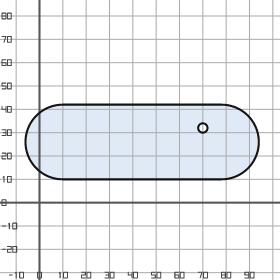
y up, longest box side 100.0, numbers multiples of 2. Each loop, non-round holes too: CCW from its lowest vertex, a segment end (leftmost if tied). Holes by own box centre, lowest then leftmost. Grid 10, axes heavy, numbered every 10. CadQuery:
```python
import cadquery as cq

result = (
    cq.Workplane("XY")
    .moveTo(10.0, 10.0)
    .lineTo(78.0, 10.0)
    .threePointArc((94.0, 26.0), (78.0, 42.0))
    .lineTo(10.0, 42.0)
    .threePointArc((-6.0, 26.0), (10.0, 10.0))
    .close()
    .moveTo(70.0, 32.0)
    .circle(2.0)
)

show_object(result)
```